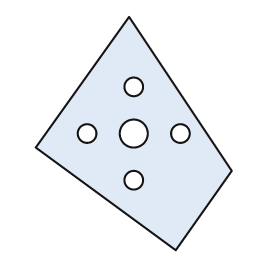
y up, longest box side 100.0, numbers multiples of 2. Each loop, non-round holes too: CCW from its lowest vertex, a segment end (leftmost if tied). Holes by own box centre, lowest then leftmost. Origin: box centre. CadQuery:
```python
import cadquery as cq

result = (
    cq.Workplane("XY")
    .moveTo(18.0, -50.0)
    .lineTo(42.0, -16.0)
    .lineTo(-2.0, 50.0)
    .lineTo(-42.0, -6.0)
    .close()
    .moveTo(0.0, -20.0)
    .circle(4.0)
    .moveTo(-20.0, 0.0)
    .circle(4.0)
    .moveTo(0.0, 0.0)
    .circle(6.0)
    .moveTo(20.0, 0.0)
    .circle(4.0)
    .moveTo(0.0, 20.0)
    .circle(4.0)
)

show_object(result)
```